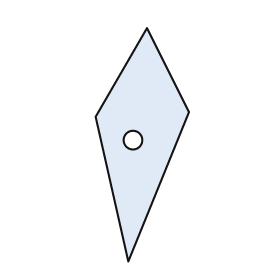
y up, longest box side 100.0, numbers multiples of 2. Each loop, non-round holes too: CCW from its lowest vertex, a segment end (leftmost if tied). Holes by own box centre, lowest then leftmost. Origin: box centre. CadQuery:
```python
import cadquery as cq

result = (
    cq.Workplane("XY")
    .moveTo(-6.0, -50.0)
    .lineTo(20.0, 14.0)
    .lineTo(2.0, 50.0)
    .lineTo(-20.0, 12.0)
    .close()
    .moveTo(-4.0, 2.0)
    .circle(4.0)
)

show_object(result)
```